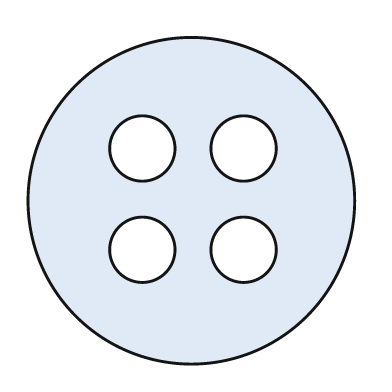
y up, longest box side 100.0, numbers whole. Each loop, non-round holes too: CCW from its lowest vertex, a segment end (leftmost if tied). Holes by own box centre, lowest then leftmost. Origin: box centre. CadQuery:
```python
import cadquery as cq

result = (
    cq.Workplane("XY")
    .moveTo(0.0, 0.0)
    .circle(50.0)
    .moveTo(-15.0, -15.0)
    .circle(10.0)
    .moveTo(16.0, -15.0)
    .circle(10.0)
    .moveTo(-15.0, 16.0)
    .circle(10.0)
    .moveTo(16.0, 16.0)
    .circle(10.0)
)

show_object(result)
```